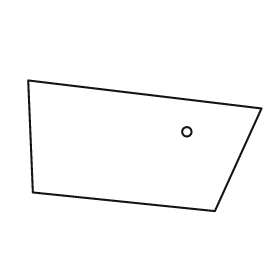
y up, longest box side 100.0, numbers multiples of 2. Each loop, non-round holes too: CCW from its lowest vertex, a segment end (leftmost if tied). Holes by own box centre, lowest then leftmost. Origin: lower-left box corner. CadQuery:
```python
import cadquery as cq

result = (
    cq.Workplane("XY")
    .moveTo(80.0, 0.0)
    .lineTo(100.0, 44.0)
    .lineTo(0.0, 56.0)
    .lineTo(2.0, 8.0)
    .close()
    .moveTo(68.0, 34.0)
    .circle(2.0)
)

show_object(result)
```